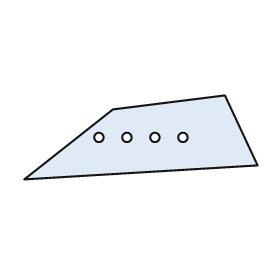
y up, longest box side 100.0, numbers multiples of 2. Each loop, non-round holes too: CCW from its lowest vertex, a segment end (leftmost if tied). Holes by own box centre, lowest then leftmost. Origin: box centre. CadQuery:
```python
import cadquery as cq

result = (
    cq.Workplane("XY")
    .moveTo(-50.0, -18.0)
    .lineTo(50.0, -12.0)
    .lineTo(36.0, 18.0)
    .lineTo(-12.0, 12.0)
    .close()
    .moveTo(-18.0, 0.0)
    .circle(2.0)
    .moveTo(-6.0, 0.0)
    .circle(2.0)
    .moveTo(6.0, 0.0)
    .circle(2.0)
    .moveTo(18.0, 0.0)
    .circle(2.0)
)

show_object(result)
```